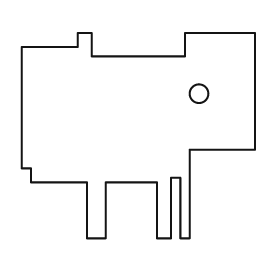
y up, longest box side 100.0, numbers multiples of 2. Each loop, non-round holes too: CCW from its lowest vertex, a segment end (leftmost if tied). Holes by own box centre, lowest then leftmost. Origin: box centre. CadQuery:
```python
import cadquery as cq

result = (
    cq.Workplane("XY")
    .moveTo(-22.0, -44.0)
    .lineTo(-14.0, -44.0)
    .lineTo(-14.0, -20.0)
    .lineTo(8.0, -20.0)
    .lineTo(8.0, -44.0)
    .lineTo(14.0, -44.0)
    .lineTo(14.0, -18.0)
    .lineTo(18.0, -18.0)
    .lineTo(18.0, -44.0)
    .lineTo(22.0, -44.0)
    .lineTo(22.0, -6.0)
    .lineTo(50.0, -6.0)
    .lineTo(50.0, 44.0)
    .lineTo(20.0, 44.0)
    .lineTo(20.0, 34.0)
    .lineTo(-20.0, 34.0)
    .lineTo(-20.0, 44.0)
    .lineTo(-26.0, 44.0)
    .lineTo(-26.0, 38.0)
    .lineTo(-50.0, 38.0)
    .lineTo(-50.0, -14.0)
    .lineTo(-46.0, -14.0)
    .lineTo(-46.0, -20.0)
    .lineTo(-22.0, -20.0)
    .close()
    .moveTo(26.0, 18.0)
    .circle(4.0)
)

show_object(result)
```